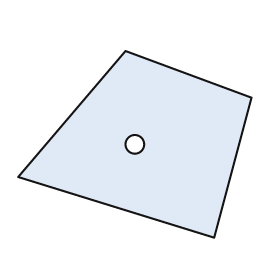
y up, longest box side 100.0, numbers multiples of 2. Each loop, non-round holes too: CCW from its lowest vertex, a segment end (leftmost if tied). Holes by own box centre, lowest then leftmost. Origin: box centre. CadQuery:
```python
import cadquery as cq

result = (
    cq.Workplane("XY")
    .moveTo(34.0, -40.0)
    .lineTo(50.0, 20.0)
    .lineTo(-4.0, 40.0)
    .lineTo(-50.0, -14.0)
    .close()
    .moveTo(0.0, 0.0)
    .circle(4.0)
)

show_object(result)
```